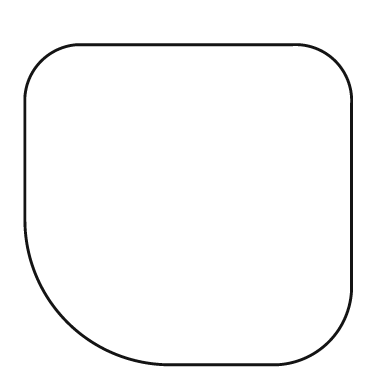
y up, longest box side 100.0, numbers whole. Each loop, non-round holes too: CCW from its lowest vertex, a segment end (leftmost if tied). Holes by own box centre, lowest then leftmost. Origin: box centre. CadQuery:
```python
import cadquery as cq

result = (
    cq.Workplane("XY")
    .moveTo(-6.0, -49.0)
    .lineTo(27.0, -49.0)
    .threePointArc((43.0, -42.0), (50.0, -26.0))
    .lineTo(50.0, 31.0)
    .threePointArc((45.0, 44.0), (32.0, 49.0))
    .lineTo(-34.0, 49.0)
    .threePointArc((-45.0, 44.0), (-50.0, 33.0))
    .lineTo(-50.0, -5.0)
    .threePointArc((-37.0, -36.0), (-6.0, -49.0))
    .close()
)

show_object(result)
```